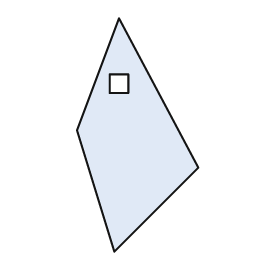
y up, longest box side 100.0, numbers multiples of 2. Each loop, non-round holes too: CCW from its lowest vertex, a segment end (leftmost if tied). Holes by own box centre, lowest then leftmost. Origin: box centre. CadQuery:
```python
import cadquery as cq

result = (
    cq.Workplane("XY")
    .moveTo(-10.0, -50.0)
    .lineTo(26.0, -14.0)
    .lineTo(-8.0, 50.0)
    .lineTo(-26.0, 2.0)
    .close()
    .moveTo(-12.0, 18.0)
    .lineTo(-4.0, 18.0)
    .lineTo(-4.0, 26.0)
    .lineTo(-12.0, 26.0)
    .close()
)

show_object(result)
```